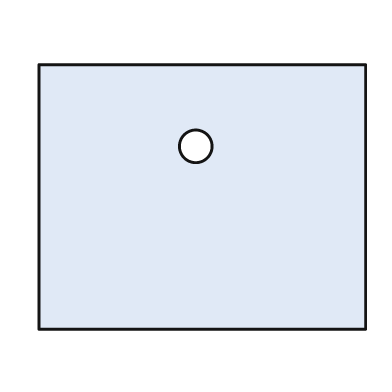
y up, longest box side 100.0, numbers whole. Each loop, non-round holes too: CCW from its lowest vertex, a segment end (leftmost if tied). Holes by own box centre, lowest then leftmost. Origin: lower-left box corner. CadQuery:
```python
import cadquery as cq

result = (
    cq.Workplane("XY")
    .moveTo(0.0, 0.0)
    .lineTo(100.0, 0.0)
    .lineTo(100.0, 81.0)
    .lineTo(0.0, 81.0)
    .close()
    .moveTo(48.0, 56.0)
    .circle(5.0)
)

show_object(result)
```